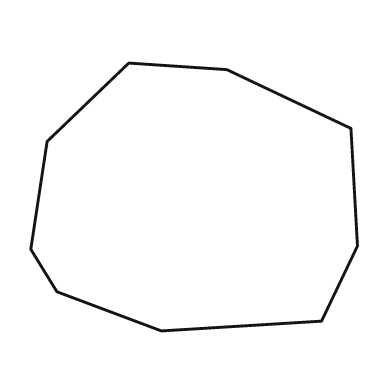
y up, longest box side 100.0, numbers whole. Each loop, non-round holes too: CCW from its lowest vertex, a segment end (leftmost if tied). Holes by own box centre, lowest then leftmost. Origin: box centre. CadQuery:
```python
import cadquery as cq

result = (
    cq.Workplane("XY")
    .moveTo(-10.0, -41.0)
    .lineTo(39.0, -38.0)
    .lineTo(50.0, -15.0)
    .lineTo(48.0, 21.0)
    .lineTo(10.0, 39.0)
    .lineTo(-20.0, 41.0)
    .lineTo(-45.0, 17.0)
    .lineTo(-50.0, -16.0)
    .lineTo(-42.0, -29.0)
    .close()
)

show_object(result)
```